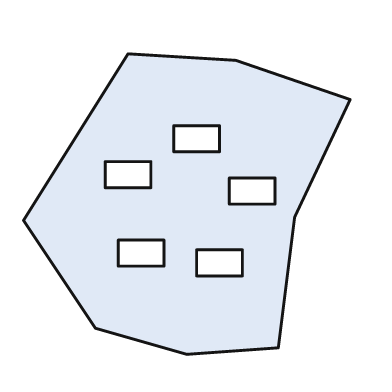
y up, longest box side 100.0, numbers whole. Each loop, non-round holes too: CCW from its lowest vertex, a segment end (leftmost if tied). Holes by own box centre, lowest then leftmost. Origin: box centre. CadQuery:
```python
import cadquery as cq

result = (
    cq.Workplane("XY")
    .moveTo(0.0, -46.0)
    .lineTo(28.0, -44.0)
    .lineTo(33.0, -4.0)
    .lineTo(50.0, 32.0)
    .lineTo(15.0, 44.0)
    .lineTo(-18.0, 46.0)
    .lineTo(-50.0, -5.0)
    .lineTo(-28.0, -38.0)
    .close()
    .moveTo(3.0, -22.0)
    .lineTo(17.0, -22.0)
    .lineTo(17.0, -14.0)
    .lineTo(3.0, -14.0)
    .close()
    .moveTo(-21.0, -19.0)
    .lineTo(-7.0, -19.0)
    .lineTo(-7.0, -11.0)
    .lineTo(-21.0, -11.0)
    .close()
    .moveTo(13.0, 0.0)
    .lineTo(27.0, 0.0)
    .lineTo(27.0, 8.0)
    .lineTo(13.0, 8.0)
    .close()
    .moveTo(-25.0, 5.0)
    .lineTo(-11.0, 5.0)
    .lineTo(-11.0, 13.0)
    .lineTo(-25.0, 13.0)
    .close()
    .moveTo(-4.0, 16.0)
    .lineTo(10.0, 16.0)
    .lineTo(10.0, 24.0)
    .lineTo(-4.0, 24.0)
    .close()
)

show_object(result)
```